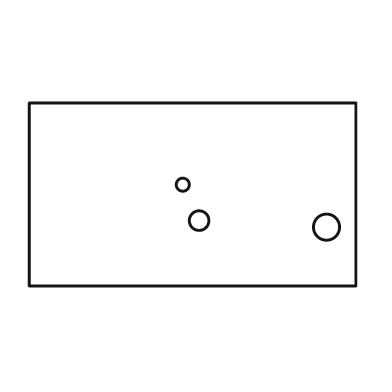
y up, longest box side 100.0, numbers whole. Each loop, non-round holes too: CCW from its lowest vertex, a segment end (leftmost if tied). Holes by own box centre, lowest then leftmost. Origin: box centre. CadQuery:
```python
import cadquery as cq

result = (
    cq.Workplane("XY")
    .moveTo(-50.0, -28.0)
    .lineTo(50.0, -28.0)
    .lineTo(50.0, 28.0)
    .lineTo(-50.0, 28.0)
    .close()
    .moveTo(41.0, -10.0)
    .circle(4.0)
    .moveTo(2.0, -8.0)
    .circle(3.0)
    .moveTo(-3.0, 3.0)
    .circle(2.0)
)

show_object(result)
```